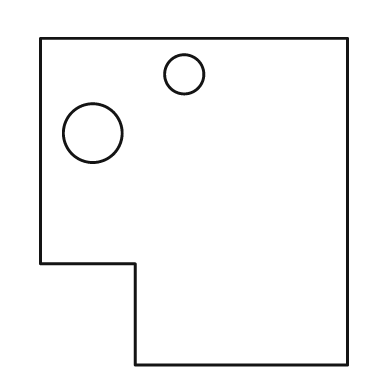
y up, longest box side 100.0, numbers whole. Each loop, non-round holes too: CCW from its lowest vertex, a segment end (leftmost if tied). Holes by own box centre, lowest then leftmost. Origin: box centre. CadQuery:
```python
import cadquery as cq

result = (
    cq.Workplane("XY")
    .moveTo(-18.0, -50.0)
    .lineTo(47.0, -50.0)
    .lineTo(47.0, 50.0)
    .lineTo(-47.0, 50.0)
    .lineTo(-47.0, -19.0)
    .lineTo(-18.0, -19.0)
    .close()
    .moveTo(-31.0, 21.0)
    .circle(9.0)
    .moveTo(-3.0, 39.0)
    .circle(6.0)
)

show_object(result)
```